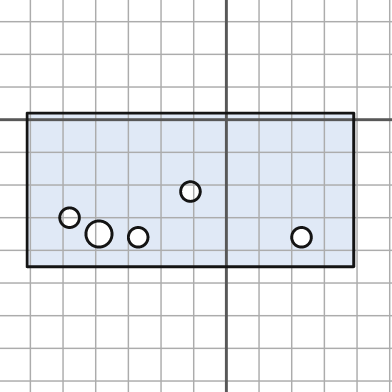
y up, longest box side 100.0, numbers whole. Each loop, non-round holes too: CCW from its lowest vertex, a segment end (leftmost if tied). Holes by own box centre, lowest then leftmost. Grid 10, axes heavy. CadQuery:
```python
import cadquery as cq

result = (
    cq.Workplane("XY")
    .moveTo(-61.0, -45.0)
    .lineTo(39.0, -45.0)
    .lineTo(39.0, 2.0)
    .lineTo(-61.0, 2.0)
    .close()
    .moveTo(-27.0, -36.0)
    .circle(3.0)
    .moveTo(23.0, -36.0)
    .circle(3.0)
    .moveTo(-39.0, -35.0)
    .circle(4.0)
    .moveTo(-48.0, -30.0)
    .circle(3.0)
    .moveTo(-11.0, -22.0)
    .circle(3.0)
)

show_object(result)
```